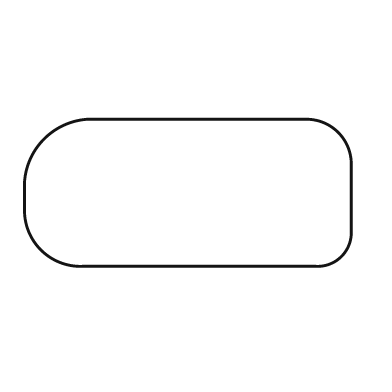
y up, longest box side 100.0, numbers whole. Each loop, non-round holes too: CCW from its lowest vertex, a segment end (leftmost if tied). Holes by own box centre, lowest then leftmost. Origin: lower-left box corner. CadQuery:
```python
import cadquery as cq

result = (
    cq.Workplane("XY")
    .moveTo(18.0, 0.0)
    .lineTo(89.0, 0.0)
    .threePointArc((97.0, 3.0), (100.0, 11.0))
    .lineTo(100.0, 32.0)
    .threePointArc((96.0, 41.0), (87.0, 45.0))
    .lineTo(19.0, 45.0)
    .threePointArc((6.0, 39.0), (0.0, 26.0))
    .lineTo(0.0, 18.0)
    .threePointArc((5.0, 5.0), (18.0, 0.0))
    .close()
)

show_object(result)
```